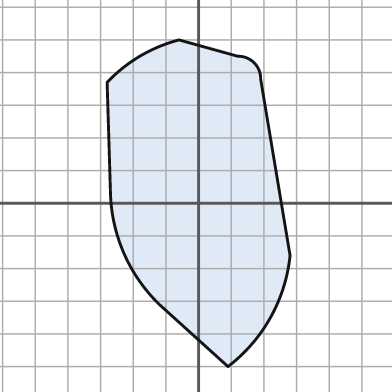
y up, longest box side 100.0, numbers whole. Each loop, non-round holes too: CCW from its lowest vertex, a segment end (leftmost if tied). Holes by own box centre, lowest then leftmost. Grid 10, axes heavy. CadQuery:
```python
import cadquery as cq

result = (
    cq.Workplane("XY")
    .moveTo(9.0, -50.0)
    .threePointArc((22.0, -35.0), (28.0, -16.0))
    .lineTo(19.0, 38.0)
    .threePointArc((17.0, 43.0), (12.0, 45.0))
    .lineTo(-6.0, 50.0)
    .threePointArc((-18.0, 45.0), (-28.0, 37.0))
    .lineTo(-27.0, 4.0)
    .threePointArc((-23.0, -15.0), (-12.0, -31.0))
    .close()
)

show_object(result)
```